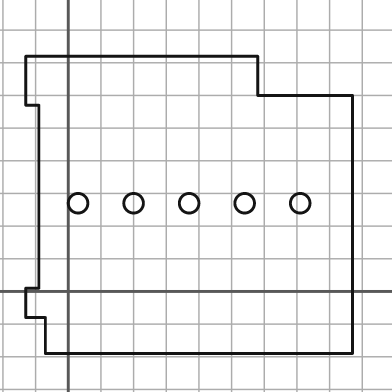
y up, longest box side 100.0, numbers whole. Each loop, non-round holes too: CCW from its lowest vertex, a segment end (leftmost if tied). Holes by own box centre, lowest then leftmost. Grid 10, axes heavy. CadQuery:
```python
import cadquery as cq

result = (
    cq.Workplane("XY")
    .moveTo(-7.0, -19.0)
    .lineTo(87.0, -19.0)
    .lineTo(87.0, 60.0)
    .lineTo(58.0, 60.0)
    .lineTo(58.0, 72.0)
    .lineTo(-13.0, 72.0)
    .lineTo(-13.0, 57.0)
    .lineTo(-9.0, 57.0)
    .lineTo(-9.0, 1.0)
    .lineTo(-13.0, 1.0)
    .lineTo(-13.0, -8.0)
    .lineTo(-7.0, -8.0)
    .close()
    .moveTo(3.0, 27.0)
    .circle(3.0)
    .moveTo(20.0, 27.0)
    .circle(3.0)
    .moveTo(37.0, 27.0)
    .circle(3.0)
    .moveTo(54.0, 27.0)
    .circle(3.0)
    .moveTo(71.0, 27.0)
    .circle(3.0)
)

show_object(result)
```